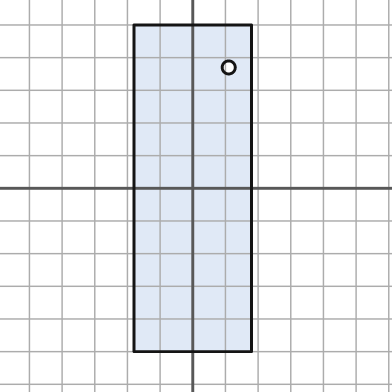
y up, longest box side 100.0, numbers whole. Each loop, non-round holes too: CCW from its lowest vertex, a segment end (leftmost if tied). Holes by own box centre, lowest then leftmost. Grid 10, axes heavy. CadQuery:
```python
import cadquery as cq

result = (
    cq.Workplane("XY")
    .moveTo(-18.0, -50.0)
    .lineTo(18.0, -50.0)
    .lineTo(18.0, 50.0)
    .lineTo(-18.0, 50.0)
    .close()
    .moveTo(11.0, 37.0)
    .circle(2.0)
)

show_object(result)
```